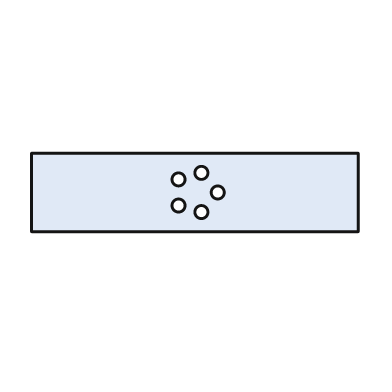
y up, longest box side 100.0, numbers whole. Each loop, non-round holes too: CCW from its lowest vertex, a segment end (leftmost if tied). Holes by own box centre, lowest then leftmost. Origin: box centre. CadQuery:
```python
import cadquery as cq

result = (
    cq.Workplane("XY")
    .moveTo(-50.0, -12.0)
    .lineTo(50.0, -12.0)
    .lineTo(50.0, 12.0)
    .lineTo(-50.0, 12.0)
    .close()
    .moveTo(2.0, -6.0)
    .circle(2.0)
    .moveTo(-5.0, -4.0)
    .circle(2.0)
    .moveTo(7.0, 0.0)
    .circle(2.0)
    .moveTo(-5.0, 4.0)
    .circle(2.0)
    .moveTo(2.0, 6.0)
    .circle(2.0)
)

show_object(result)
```